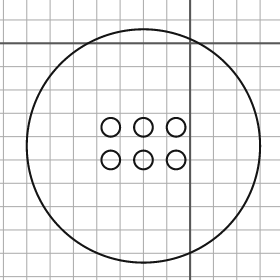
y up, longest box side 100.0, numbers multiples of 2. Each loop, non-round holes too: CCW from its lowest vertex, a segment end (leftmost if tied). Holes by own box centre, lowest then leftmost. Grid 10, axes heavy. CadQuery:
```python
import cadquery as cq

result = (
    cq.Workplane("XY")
    .moveTo(-20.0, -44.0)
    .circle(50.0)
    .moveTo(-34.0, -50.0)
    .circle(4.0)
    .moveTo(-20.0, -50.0)
    .circle(4.0)
    .moveTo(-6.0, -50.0)
    .circle(4.0)
    .moveTo(-34.0, -36.0)
    .circle(4.0)
    .moveTo(-20.0, -36.0)
    .circle(4.0)
    .moveTo(-6.0, -36.0)
    .circle(4.0)
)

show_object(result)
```